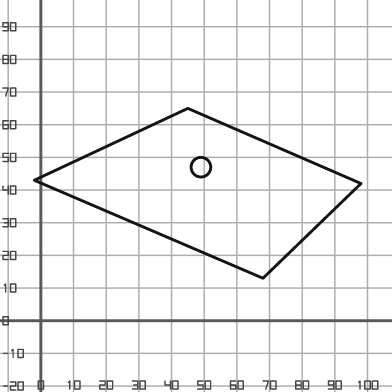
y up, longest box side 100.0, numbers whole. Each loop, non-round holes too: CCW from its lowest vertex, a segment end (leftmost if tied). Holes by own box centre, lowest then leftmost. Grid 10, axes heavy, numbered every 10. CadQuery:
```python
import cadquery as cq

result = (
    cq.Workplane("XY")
    .moveTo(68.0, 13.0)
    .lineTo(98.0, 42.0)
    .lineTo(45.0, 65.0)
    .lineTo(-2.0, 43.0)
    .close()
    .moveTo(49.0, 47.0)
    .circle(3.0)
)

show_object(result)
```